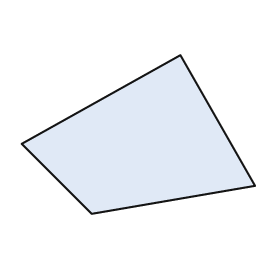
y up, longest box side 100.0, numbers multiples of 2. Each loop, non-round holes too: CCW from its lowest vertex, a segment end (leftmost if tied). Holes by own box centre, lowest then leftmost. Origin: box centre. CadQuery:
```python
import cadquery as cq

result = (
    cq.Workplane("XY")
    .moveTo(-20.0, -34.0)
    .lineTo(50.0, -22.0)
    .lineTo(18.0, 34.0)
    .lineTo(-50.0, -4.0)
    .close()
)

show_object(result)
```